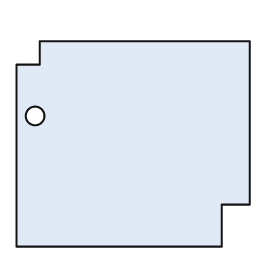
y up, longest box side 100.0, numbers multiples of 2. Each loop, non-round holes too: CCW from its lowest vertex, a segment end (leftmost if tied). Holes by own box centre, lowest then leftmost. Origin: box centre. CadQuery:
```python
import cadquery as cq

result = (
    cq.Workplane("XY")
    .moveTo(-50.0, -44.0)
    .lineTo(38.0, -44.0)
    .lineTo(38.0, -26.0)
    .lineTo(50.0, -26.0)
    .lineTo(50.0, 44.0)
    .lineTo(-40.0, 44.0)
    .lineTo(-40.0, 34.0)
    .lineTo(-50.0, 34.0)
    .close()
    .moveTo(-42.0, 12.0)
    .circle(4.0)
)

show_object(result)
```